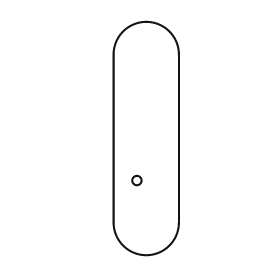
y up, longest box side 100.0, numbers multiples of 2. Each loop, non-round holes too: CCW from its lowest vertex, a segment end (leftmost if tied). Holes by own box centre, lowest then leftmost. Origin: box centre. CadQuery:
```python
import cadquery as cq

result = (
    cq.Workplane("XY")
    .moveTo(-14.0, -36.0)
    .threePointArc((0.0, -50.0), (14.0, -36.0))
    .lineTo(14.0, 36.0)
    .threePointArc((0.0, 50.0), (-14.0, 36.0))
    .close()
    .moveTo(-4.0, -18.0)
    .circle(2.0)
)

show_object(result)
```